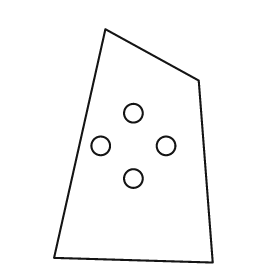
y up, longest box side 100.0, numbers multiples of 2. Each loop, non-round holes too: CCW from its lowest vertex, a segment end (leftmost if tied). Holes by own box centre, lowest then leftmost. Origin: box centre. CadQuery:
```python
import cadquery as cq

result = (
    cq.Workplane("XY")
    .moveTo(34.0, -50.0)
    .lineTo(28.0, 28.0)
    .lineTo(-12.0, 50.0)
    .lineTo(-34.0, -48.0)
    .close()
    .moveTo(0.0, -14.0)
    .circle(4.0)
    .moveTo(-14.0, 0.0)
    .circle(4.0)
    .moveTo(14.0, 0.0)
    .circle(4.0)
    .moveTo(0.0, 14.0)
    .circle(4.0)
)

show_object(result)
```